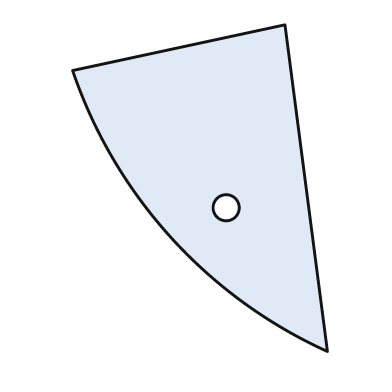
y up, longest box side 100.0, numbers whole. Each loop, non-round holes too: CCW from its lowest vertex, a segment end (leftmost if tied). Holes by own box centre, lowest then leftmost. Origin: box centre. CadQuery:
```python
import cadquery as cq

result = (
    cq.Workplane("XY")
    .moveTo(39.0, -50.0)
    .lineTo(26.0, 50.0)
    .lineTo(-39.0, 36.0)
    .threePointArc((-9.0, -15.0), (39.0, -50.0))
    .close()
    .moveTo(8.0, -6.0)
    .circle(4.0)
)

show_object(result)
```